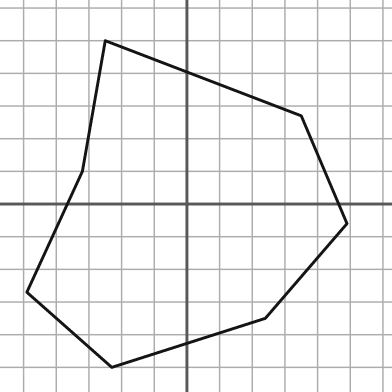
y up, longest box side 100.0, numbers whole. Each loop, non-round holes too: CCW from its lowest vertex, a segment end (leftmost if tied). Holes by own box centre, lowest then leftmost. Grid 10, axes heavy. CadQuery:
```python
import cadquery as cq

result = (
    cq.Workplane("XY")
    .moveTo(-23.0, -50.0)
    .lineTo(24.0, -35.0)
    .lineTo(49.0, -6.0)
    .lineTo(35.0, 27.0)
    .lineTo(-25.0, 50.0)
    .lineTo(-32.0, 10.0)
    .lineTo(-49.0, -27.0)
    .close()
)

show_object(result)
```